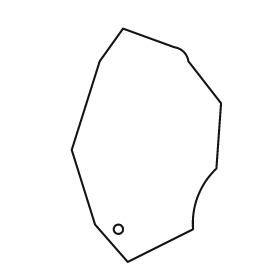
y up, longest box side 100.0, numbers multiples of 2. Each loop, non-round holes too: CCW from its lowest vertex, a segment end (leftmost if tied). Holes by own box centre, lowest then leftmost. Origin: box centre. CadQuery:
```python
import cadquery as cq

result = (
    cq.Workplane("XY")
    .moveTo(-8.0, -50.0)
    .lineTo(20.0, -36.0)
    .threePointArc((22.0, -22.0), (30.0, -10.0))
    .lineTo(32.0, 18.0)
    .lineTo(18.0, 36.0)
    .threePointArc((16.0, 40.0), (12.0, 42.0))
    .lineTo(-10.0, 50.0)
    .lineTo(-20.0, 36.0)
    .lineTo(-32.0, -2.0)
    .lineTo(-22.0, -34.0)
    .close()
    .moveTo(-12.0, -36.0)
    .circle(2.0)
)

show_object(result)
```